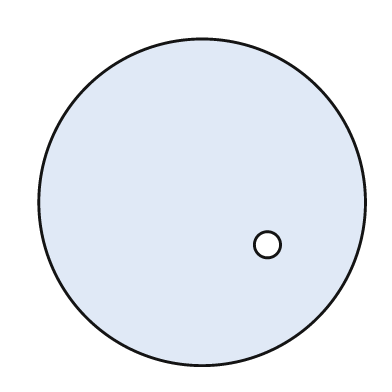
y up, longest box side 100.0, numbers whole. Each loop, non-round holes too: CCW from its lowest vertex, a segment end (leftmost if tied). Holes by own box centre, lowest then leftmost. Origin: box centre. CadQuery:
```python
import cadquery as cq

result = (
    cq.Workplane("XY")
    .moveTo(0.0, 0.0)
    .circle(50.0)
    .moveTo(20.0, -13.0)
    .circle(4.0)
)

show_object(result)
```